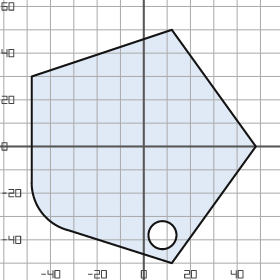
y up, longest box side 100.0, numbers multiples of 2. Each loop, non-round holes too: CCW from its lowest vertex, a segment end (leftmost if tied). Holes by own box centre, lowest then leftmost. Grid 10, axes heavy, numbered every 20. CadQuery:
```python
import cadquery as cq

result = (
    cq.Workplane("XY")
    .moveTo(12.0, -50.0)
    .lineTo(48.0, 0.0)
    .lineTo(12.0, 50.0)
    .lineTo(-48.0, 30.0)
    .lineTo(-48.0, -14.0)
    .threePointArc((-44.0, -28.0), (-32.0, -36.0))
    .close()
    .moveTo(8.0, -38.0)
    .circle(6.0)
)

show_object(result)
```